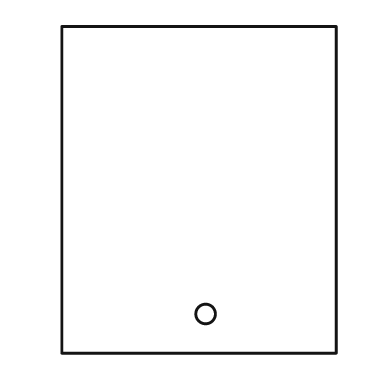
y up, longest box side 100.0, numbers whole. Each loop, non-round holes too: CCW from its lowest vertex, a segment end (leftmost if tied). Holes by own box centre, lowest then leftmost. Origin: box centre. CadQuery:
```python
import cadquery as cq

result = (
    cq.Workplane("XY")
    .moveTo(-42.0, -50.0)
    .lineTo(42.0, -50.0)
    .lineTo(42.0, 50.0)
    .lineTo(-42.0, 50.0)
    .close()
    .moveTo(2.0, -38.0)
    .circle(3.0)
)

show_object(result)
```